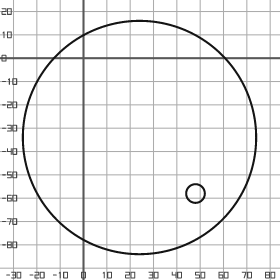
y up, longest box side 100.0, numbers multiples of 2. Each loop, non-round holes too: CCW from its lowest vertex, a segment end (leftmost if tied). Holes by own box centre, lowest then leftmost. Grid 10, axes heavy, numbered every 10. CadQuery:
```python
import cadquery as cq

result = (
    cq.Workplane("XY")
    .moveTo(24.0, -34.0)
    .circle(50.0)
    .moveTo(48.0, -58.0)
    .circle(4.0)
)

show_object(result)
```